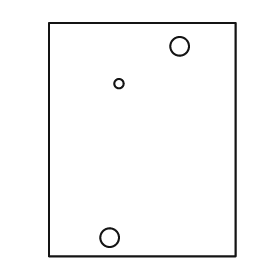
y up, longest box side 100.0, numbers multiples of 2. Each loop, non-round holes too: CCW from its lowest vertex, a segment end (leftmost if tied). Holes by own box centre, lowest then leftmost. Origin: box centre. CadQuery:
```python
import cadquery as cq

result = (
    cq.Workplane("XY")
    .moveTo(-40.0, -50.0)
    .lineTo(40.0, -50.0)
    .lineTo(40.0, 50.0)
    .lineTo(-40.0, 50.0)
    .close()
    .moveTo(-14.0, -42.0)
    .circle(4.0)
    .moveTo(-10.0, 24.0)
    .circle(2.0)
    .moveTo(16.0, 40.0)
    .circle(4.0)
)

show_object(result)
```